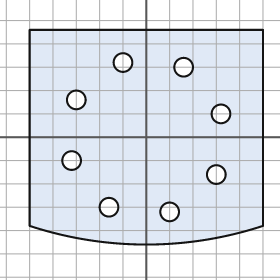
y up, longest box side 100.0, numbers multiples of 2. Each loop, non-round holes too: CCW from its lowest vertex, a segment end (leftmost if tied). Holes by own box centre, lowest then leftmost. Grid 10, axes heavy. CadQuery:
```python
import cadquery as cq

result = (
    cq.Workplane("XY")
    .moveTo(-50.0, -38.0)
    .threePointArc((0.0, -46.0), (50.0, -38.0))
    .lineTo(50.0, 46.0)
    .lineTo(-50.0, 46.0)
    .close()
    .moveTo(10.0, -32.0)
    .circle(4.0)
    .moveTo(-16.0, -30.0)
    .circle(4.0)
    .moveTo(30.0, -16.0)
    .circle(4.0)
    .moveTo(-32.0, -10.0)
    .circle(4.0)
    .moveTo(32.0, 10.0)
    .circle(4.0)
    .moveTo(-30.0, 16.0)
    .circle(4.0)
    .moveTo(16.0, 30.0)
    .circle(4.0)
    .moveTo(-10.0, 32.0)
    .circle(4.0)
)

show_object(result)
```